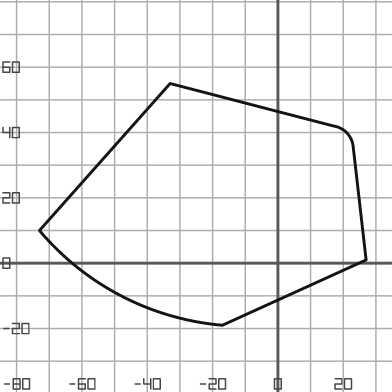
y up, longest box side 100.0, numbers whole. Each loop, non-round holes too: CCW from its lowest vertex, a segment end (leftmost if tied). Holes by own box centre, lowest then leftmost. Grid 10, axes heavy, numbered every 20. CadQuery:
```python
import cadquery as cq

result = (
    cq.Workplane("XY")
    .moveTo(-17.0, -19.0)
    .lineTo(27.0, 1.0)
    .lineTo(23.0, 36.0)
    .threePointArc((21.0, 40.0), (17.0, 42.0))
    .lineTo(-33.0, 55.0)
    .lineTo(-73.0, 10.0)
    .threePointArc((-48.0, -10.0), (-17.0, -19.0))
    .close()
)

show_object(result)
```